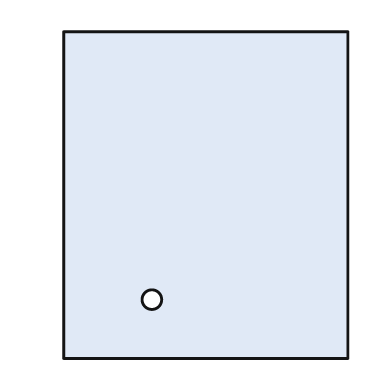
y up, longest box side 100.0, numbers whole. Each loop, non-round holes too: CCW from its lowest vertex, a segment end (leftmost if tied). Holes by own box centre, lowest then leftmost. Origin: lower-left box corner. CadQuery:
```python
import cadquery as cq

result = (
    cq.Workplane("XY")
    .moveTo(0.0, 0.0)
    .lineTo(87.0, 0.0)
    .lineTo(87.0, 100.0)
    .lineTo(0.0, 100.0)
    .close()
    .moveTo(27.0, 18.0)
    .circle(3.0)
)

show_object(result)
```